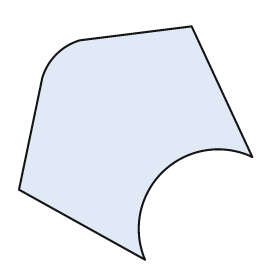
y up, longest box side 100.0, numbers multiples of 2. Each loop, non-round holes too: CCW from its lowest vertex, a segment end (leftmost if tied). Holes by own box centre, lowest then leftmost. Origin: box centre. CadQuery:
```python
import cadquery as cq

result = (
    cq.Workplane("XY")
    .moveTo(4.0, -50.0)
    .threePointArc((12.0, -12.0), (50.0, -6.0))
    .lineTo(24.0, 50.0)
    .lineTo(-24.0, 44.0)
    .threePointArc((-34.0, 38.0), (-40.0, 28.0))
    .lineTo(-50.0, -20.0)
    .close()
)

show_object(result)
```